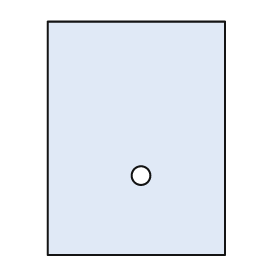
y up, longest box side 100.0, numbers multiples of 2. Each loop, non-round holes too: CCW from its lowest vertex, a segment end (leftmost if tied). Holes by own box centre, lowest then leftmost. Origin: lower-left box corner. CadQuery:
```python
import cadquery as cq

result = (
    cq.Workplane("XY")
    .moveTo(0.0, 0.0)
    .lineTo(76.0, 0.0)
    .lineTo(76.0, 100.0)
    .lineTo(0.0, 100.0)
    .close()
    .moveTo(40.0, 34.0)
    .circle(4.0)
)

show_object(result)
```